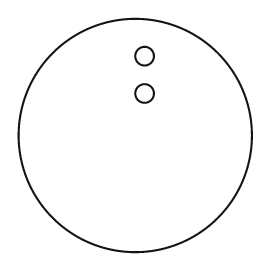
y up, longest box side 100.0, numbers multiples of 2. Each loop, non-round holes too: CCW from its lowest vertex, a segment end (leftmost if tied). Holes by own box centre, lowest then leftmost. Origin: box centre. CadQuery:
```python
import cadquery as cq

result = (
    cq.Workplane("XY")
    .moveTo(0.0, 0.0)
    .circle(50.0)
    .moveTo(4.0, 18.0)
    .circle(4.0)
    .moveTo(4.0, 34.0)
    .circle(4.0)
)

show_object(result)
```